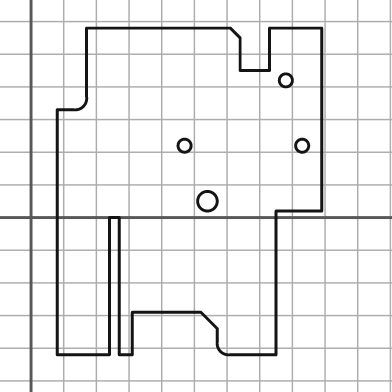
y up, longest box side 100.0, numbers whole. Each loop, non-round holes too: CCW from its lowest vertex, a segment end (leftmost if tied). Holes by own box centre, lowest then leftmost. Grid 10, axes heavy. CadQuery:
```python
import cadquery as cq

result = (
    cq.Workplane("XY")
    .moveTo(8.0, -42.0)
    .lineTo(24.0, -42.0)
    .lineTo(24.0, 0.0)
    .lineTo(27.0, 0.0)
    .lineTo(27.0, -42.0)
    .lineTo(31.0, -42.0)
    .lineTo(31.0, -29.0)
    .lineTo(52.0, -29.0)
    .lineTo(57.0, -34.0)
    .lineTo(57.0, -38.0)
    .threePointArc((58.0, -41.0), (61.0, -42.0))
    .lineTo(75.0, -42.0)
    .lineTo(75.0, 2.0)
    .lineTo(89.0, 2.0)
    .lineTo(89.0, 58.0)
    .lineTo(73.0, 58.0)
    .lineTo(73.0, 45.0)
    .lineTo(64.0, 45.0)
    .lineTo(64.0, 55.0)
    .lineTo(61.0, 58.0)
    .lineTo(17.0, 58.0)
    .lineTo(17.0, 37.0)
    .threePointArc((16.0, 34.0), (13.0, 33.0))
    .lineTo(8.0, 33.0)
    .close()
    .moveTo(54.0, 5.0)
    .circle(3.0)
    .moveTo(47.0, 22.0)
    .circle(2.0)
    .moveTo(83.0, 22.0)
    .circle(2.0)
    .moveTo(78.0, 42.0)
    .circle(2.0)
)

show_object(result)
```